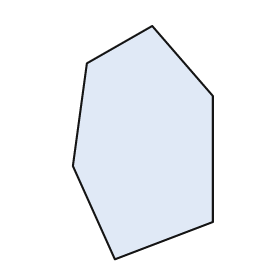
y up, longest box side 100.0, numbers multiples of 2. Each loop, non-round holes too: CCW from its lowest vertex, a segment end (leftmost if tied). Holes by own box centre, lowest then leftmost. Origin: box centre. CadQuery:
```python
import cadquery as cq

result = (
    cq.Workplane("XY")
    .moveTo(-12.0, -50.0)
    .lineTo(30.0, -34.0)
    .lineTo(30.0, 20.0)
    .lineTo(4.0, 50.0)
    .lineTo(-24.0, 34.0)
    .lineTo(-30.0, -10.0)
    .close()
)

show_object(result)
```